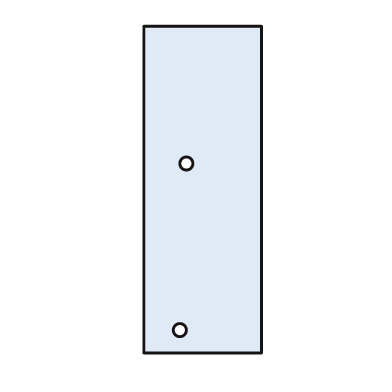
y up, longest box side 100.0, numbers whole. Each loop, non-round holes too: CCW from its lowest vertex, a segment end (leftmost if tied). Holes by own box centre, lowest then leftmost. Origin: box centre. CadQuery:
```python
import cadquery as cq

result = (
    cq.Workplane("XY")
    .moveTo(-18.0, -50.0)
    .lineTo(18.0, -50.0)
    .lineTo(18.0, 50.0)
    .lineTo(-18.0, 50.0)
    .close()
    .moveTo(-7.0, -43.0)
    .circle(2.0)
    .moveTo(-5.0, 8.0)
    .circle(2.0)
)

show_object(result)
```